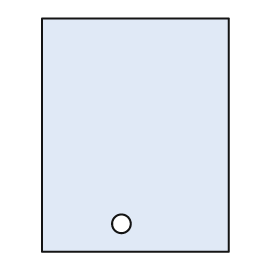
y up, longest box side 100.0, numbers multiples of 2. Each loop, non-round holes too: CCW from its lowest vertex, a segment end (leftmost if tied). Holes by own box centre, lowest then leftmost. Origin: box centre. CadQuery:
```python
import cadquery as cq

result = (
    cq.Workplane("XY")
    .moveTo(-40.0, -50.0)
    .lineTo(40.0, -50.0)
    .lineTo(40.0, 50.0)
    .lineTo(-40.0, 50.0)
    .close()
    .moveTo(-6.0, -38.0)
    .circle(4.0)
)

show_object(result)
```